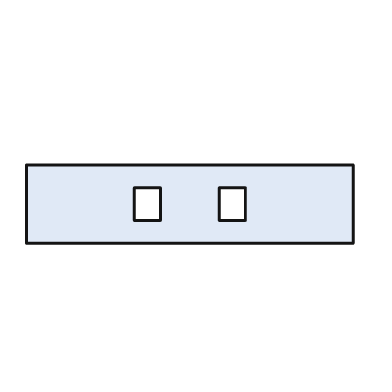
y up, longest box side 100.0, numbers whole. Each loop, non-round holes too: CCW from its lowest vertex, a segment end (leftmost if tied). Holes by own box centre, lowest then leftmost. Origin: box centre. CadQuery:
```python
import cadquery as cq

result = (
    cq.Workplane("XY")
    .moveTo(-50.0, -12.0)
    .lineTo(50.0, -12.0)
    .lineTo(50.0, 12.0)
    .lineTo(-50.0, 12.0)
    .close()
    .moveTo(-17.0, -5.0)
    .lineTo(-9.0, -5.0)
    .lineTo(-9.0, 5.0)
    .lineTo(-17.0, 5.0)
    .close()
    .moveTo(9.0, -5.0)
    .lineTo(17.0, -5.0)
    .lineTo(17.0, 5.0)
    .lineTo(9.0, 5.0)
    .close()
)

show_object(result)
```